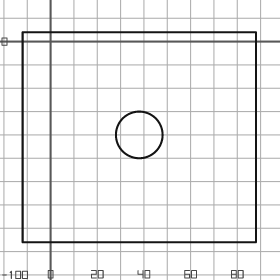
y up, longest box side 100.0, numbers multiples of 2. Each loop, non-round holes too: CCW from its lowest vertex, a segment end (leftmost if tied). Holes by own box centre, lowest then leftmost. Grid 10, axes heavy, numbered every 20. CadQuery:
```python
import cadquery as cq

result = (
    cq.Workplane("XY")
    .moveTo(-12.0, -86.0)
    .lineTo(88.0, -86.0)
    .lineTo(88.0, 4.0)
    .lineTo(-12.0, 4.0)
    .close()
    .moveTo(38.0, -40.0)
    .circle(10.0)
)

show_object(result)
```